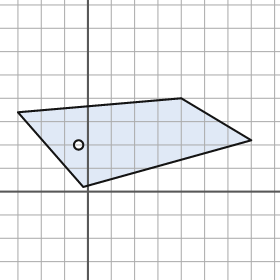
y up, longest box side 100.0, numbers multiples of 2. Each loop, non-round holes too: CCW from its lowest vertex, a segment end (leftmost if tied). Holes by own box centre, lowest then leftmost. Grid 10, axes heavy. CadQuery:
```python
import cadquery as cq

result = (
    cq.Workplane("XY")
    .moveTo(-2.0, 2.0)
    .lineTo(70.0, 22.0)
    .lineTo(40.0, 40.0)
    .lineTo(-30.0, 34.0)
    .close()
    .moveTo(-4.0, 20.0)
    .circle(2.0)
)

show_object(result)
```